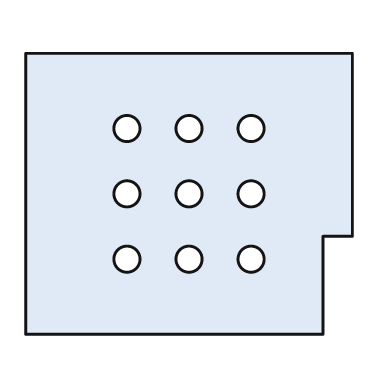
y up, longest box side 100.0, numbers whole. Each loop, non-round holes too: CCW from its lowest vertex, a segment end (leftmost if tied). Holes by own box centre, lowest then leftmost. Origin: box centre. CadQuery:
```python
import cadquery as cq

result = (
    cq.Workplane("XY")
    .moveTo(-50.0, -43.0)
    .lineTo(41.0, -43.0)
    .lineTo(41.0, -13.0)
    .lineTo(50.0, -13.0)
    .lineTo(50.0, 43.0)
    .lineTo(-50.0, 43.0)
    .close()
    .moveTo(-19.0, -20.0)
    .circle(4.0)
    .moveTo(0.0, -20.0)
    .circle(4.0)
    .moveTo(19.0, -20.0)
    .circle(4.0)
    .moveTo(-19.0, 0.0)
    .circle(4.0)
    .moveTo(0.0, 0.0)
    .circle(4.0)
    .moveTo(19.0, 0.0)
    .circle(4.0)
    .moveTo(-19.0, 20.0)
    .circle(4.0)
    .moveTo(0.0, 20.0)
    .circle(4.0)
    .moveTo(19.0, 20.0)
    .circle(4.0)
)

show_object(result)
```